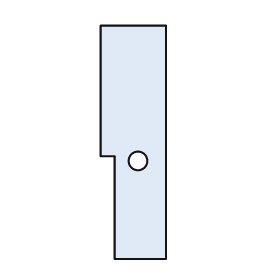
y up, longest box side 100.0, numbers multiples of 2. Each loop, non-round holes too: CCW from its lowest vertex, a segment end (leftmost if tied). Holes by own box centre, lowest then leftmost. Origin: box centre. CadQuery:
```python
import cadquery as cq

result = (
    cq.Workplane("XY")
    .moveTo(-8.0, -50.0)
    .lineTo(14.0, -50.0)
    .lineTo(14.0, 50.0)
    .lineTo(-14.0, 50.0)
    .lineTo(-14.0, -6.0)
    .lineTo(-8.0, -6.0)
    .close()
    .moveTo(2.0, -8.0)
    .circle(4.0)
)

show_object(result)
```